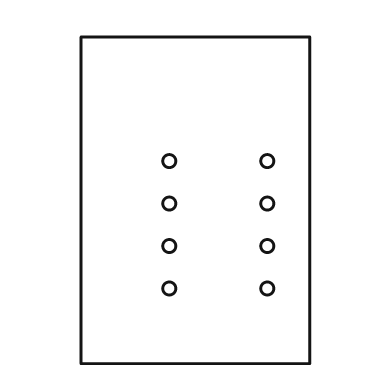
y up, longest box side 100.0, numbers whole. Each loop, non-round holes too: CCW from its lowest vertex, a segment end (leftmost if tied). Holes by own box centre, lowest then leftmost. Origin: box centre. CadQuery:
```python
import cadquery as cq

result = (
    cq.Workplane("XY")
    .moveTo(-35.0, -50.0)
    .lineTo(35.0, -50.0)
    .lineTo(35.0, 50.0)
    .lineTo(-35.0, 50.0)
    .close()
    .moveTo(-8.0, -27.0)
    .circle(2.0)
    .moveTo(22.0, -27.0)
    .circle(2.0)
    .moveTo(-8.0, -14.0)
    .circle(2.0)
    .moveTo(22.0, -14.0)
    .circle(2.0)
    .moveTo(-8.0, -1.0)
    .circle(2.0)
    .moveTo(22.0, -1.0)
    .circle(2.0)
    .moveTo(-8.0, 12.0)
    .circle(2.0)
    .moveTo(22.0, 12.0)
    .circle(2.0)
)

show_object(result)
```